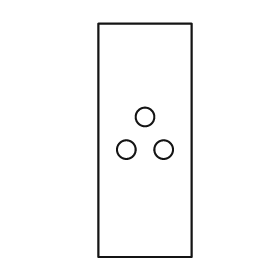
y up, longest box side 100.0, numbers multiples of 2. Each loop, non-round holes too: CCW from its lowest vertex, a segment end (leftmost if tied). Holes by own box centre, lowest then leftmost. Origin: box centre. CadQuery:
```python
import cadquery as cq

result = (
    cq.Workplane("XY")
    .moveTo(-20.0, -50.0)
    .lineTo(20.0, -50.0)
    .lineTo(20.0, 50.0)
    .lineTo(-20.0, 50.0)
    .close()
    .moveTo(-8.0, -4.0)
    .circle(4.0)
    .moveTo(8.0, -4.0)
    .circle(4.0)
    .moveTo(0.0, 10.0)
    .circle(4.0)
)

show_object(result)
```